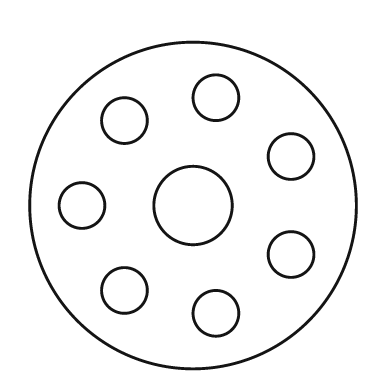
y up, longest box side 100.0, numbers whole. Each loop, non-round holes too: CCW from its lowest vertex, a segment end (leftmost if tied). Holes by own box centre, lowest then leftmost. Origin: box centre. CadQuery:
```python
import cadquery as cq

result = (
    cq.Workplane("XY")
    .moveTo(0.0, 0.0)
    .circle(50.0)
    .moveTo(7.0, -33.0)
    .circle(7.0)
    .moveTo(-21.0, -26.0)
    .circle(7.0)
    .moveTo(30.0, -15.0)
    .circle(7.0)
    .moveTo(-34.0, 0.0)
    .circle(7.0)
    .moveTo(0.0, 0.0)
    .circle(12.0)
    .moveTo(30.0, 15.0)
    .circle(7.0)
    .moveTo(-21.0, 26.0)
    .circle(7.0)
    .moveTo(7.0, 33.0)
    .circle(7.0)
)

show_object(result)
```